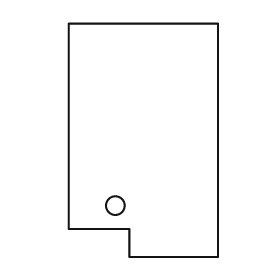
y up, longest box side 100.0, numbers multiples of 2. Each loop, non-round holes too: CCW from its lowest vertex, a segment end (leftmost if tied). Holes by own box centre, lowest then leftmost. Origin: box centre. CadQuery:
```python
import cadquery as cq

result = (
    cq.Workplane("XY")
    .moveTo(-6.0, -50.0)
    .lineTo(32.0, -50.0)
    .lineTo(32.0, 50.0)
    .lineTo(-32.0, 50.0)
    .lineTo(-32.0, -38.0)
    .lineTo(-6.0, -38.0)
    .close()
    .moveTo(-12.0, -28.0)
    .circle(4.0)
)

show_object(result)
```